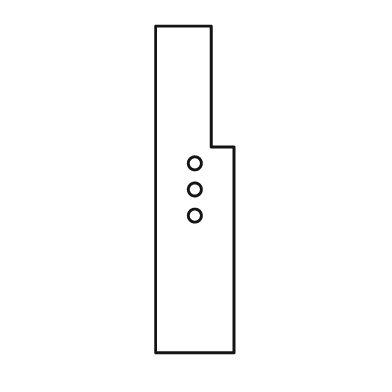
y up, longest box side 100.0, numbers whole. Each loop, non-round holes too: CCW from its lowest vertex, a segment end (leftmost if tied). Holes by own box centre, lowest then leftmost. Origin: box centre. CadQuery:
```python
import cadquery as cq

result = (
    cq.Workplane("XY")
    .moveTo(-12.0, -50.0)
    .lineTo(12.0, -50.0)
    .lineTo(12.0, 13.0)
    .lineTo(5.0, 13.0)
    .lineTo(5.0, 50.0)
    .lineTo(-12.0, 50.0)
    .close()
    .moveTo(0.0, -8.0)
    .circle(2.0)
    .moveTo(0.0, 0.0)
    .circle(2.0)
    .moveTo(0.0, 8.0)
    .circle(2.0)
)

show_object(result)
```